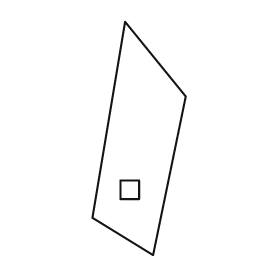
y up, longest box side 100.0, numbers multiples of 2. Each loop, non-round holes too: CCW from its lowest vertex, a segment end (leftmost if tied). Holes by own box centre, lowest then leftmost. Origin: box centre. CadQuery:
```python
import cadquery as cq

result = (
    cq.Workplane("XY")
    .moveTo(6.0, -50.0)
    .lineTo(20.0, 18.0)
    .lineTo(-6.0, 50.0)
    .lineTo(-20.0, -34.0)
    .close()
    .moveTo(-8.0, -26.0)
    .lineTo(0.0, -26.0)
    .lineTo(0.0, -18.0)
    .lineTo(-8.0, -18.0)
    .close()
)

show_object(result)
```